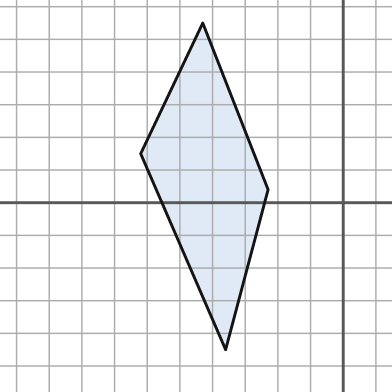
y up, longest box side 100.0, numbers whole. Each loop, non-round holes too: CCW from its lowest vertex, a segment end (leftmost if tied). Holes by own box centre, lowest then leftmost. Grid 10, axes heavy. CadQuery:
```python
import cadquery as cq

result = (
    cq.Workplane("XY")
    .moveTo(-36.0, -45.0)
    .lineTo(-23.0, 4.0)
    .lineTo(-43.0, 55.0)
    .lineTo(-62.0, 15.0)
    .close()
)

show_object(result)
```